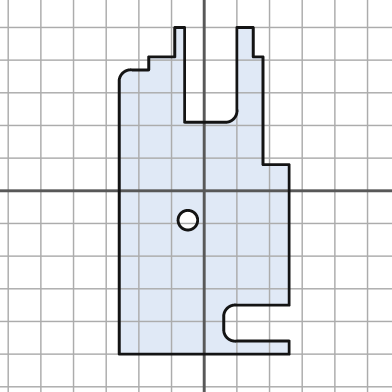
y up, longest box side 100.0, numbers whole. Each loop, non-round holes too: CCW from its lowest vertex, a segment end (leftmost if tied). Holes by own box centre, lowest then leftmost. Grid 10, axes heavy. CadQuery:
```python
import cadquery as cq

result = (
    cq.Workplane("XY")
    .moveTo(-26.0, -50.0)
    .lineTo(26.0, -50.0)
    .lineTo(26.0, -46.0)
    .lineTo(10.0, -46.0)
    .threePointArc((7.0, -45.0), (6.0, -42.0))
    .lineTo(6.0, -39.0)
    .threePointArc((7.0, -36.0), (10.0, -35.0))
    .lineTo(26.0, -35.0)
    .lineTo(26.0, 8.0)
    .lineTo(18.0, 8.0)
    .lineTo(18.0, 41.0)
    .lineTo(15.0, 41.0)
    .lineTo(15.0, 50.0)
    .lineTo(10.0, 50.0)
    .lineTo(10.0, 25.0)
    .threePointArc((9.0, 22.0), (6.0, 21.0))
    .lineTo(-6.0, 21.0)
    .lineTo(-6.0, 50.0)
    .lineTo(-9.0, 50.0)
    .lineTo(-9.0, 41.0)
    .lineTo(-17.0, 41.0)
    .lineTo(-17.0, 37.0)
    .lineTo(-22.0, 37.0)
    .threePointArc((-25.0, 36.0), (-26.0, 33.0))
    .close()
    .moveTo(-5.0, -9.0)
    .circle(3.0)
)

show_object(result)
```